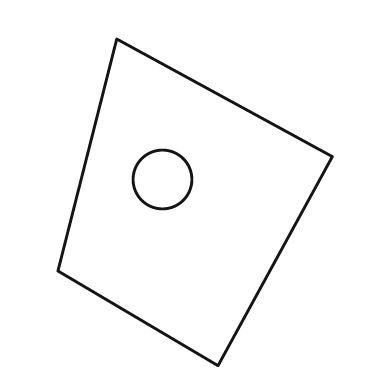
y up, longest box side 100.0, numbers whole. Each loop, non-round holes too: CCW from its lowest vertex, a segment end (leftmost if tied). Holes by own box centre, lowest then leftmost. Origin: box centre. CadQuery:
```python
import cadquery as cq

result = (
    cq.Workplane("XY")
    .moveTo(7.0, -50.0)
    .lineTo(42.0, 14.0)
    .lineTo(-24.0, 50.0)
    .lineTo(-42.0, -21.0)
    .close()
    .moveTo(-10.0, 7.0)
    .circle(9.0)
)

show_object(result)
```